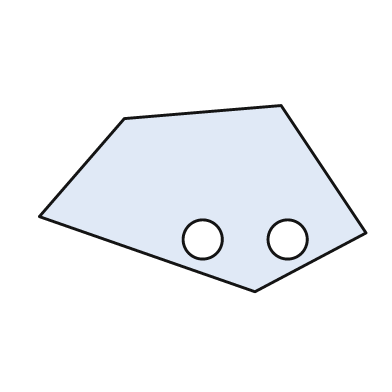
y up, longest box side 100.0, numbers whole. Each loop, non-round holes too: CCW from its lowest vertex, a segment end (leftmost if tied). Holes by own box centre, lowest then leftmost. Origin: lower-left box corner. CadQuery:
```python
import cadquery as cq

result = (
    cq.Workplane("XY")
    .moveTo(66.0, 0.0)
    .lineTo(100.0, 18.0)
    .lineTo(74.0, 57.0)
    .lineTo(26.0, 53.0)
    .lineTo(0.0, 23.0)
    .close()
    .moveTo(50.0, 16.0)
    .circle(6.0)
    .moveTo(76.0, 16.0)
    .circle(6.0)
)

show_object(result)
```